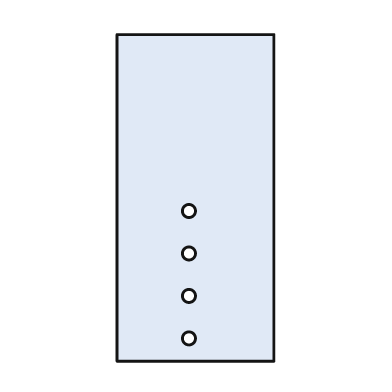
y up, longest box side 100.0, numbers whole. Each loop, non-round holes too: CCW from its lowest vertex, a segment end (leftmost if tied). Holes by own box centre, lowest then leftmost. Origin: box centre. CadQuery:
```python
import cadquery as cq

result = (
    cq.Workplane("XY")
    .moveTo(-24.0, -50.0)
    .lineTo(24.0, -50.0)
    .lineTo(24.0, 50.0)
    .lineTo(-24.0, 50.0)
    .close()
    .moveTo(-2.0, -43.0)
    .circle(2.0)
    .moveTo(-2.0, -30.0)
    .circle(2.0)
    .moveTo(-2.0, -17.0)
    .circle(2.0)
    .moveTo(-2.0, -4.0)
    .circle(2.0)
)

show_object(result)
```